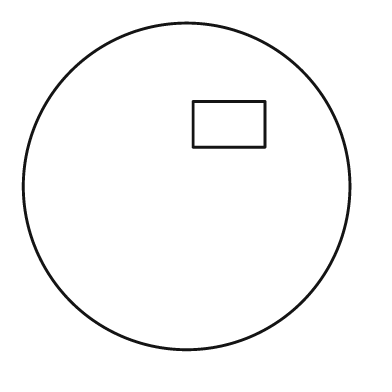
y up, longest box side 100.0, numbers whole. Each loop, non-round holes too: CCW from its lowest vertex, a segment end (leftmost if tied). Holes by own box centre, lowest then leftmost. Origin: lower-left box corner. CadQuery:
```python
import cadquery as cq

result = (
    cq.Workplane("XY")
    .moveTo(50.0, 50.0)
    .circle(50.0)
    .moveTo(52.0, 62.0)
    .lineTo(74.0, 62.0)
    .lineTo(74.0, 76.0)
    .lineTo(52.0, 76.0)
    .close()
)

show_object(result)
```